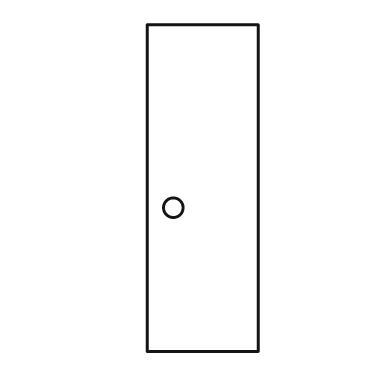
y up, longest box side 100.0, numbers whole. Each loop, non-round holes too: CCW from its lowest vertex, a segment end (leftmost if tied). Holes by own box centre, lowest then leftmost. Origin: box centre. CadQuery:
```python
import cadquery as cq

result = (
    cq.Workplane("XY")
    .moveTo(-17.0, -50.0)
    .lineTo(17.0, -50.0)
    .lineTo(17.0, 50.0)
    .lineTo(-17.0, 50.0)
    .close()
    .moveTo(-9.0, -6.0)
    .circle(3.0)
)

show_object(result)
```